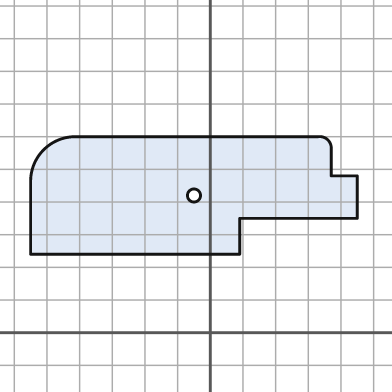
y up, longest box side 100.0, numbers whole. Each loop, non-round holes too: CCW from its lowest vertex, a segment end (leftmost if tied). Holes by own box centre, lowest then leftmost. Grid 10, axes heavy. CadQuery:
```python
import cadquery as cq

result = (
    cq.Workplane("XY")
    .moveTo(-55.0, 24.0)
    .lineTo(9.0, 24.0)
    .lineTo(9.0, 35.0)
    .lineTo(45.0, 35.0)
    .lineTo(45.0, 48.0)
    .lineTo(37.0, 48.0)
    .lineTo(37.0, 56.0)
    .threePointArc((36.0, 59.0), (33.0, 60.0))
    .lineTo(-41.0, 60.0)
    .threePointArc((-51.0, 56.0), (-55.0, 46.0))
    .close()
    .moveTo(-5.0, 42.0)
    .circle(2.0)
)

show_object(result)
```